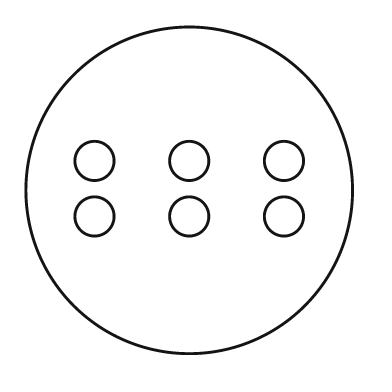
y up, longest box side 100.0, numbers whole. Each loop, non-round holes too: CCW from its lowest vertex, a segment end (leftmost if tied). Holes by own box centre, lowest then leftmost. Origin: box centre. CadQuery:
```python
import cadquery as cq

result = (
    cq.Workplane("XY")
    .moveTo(0.0, 0.0)
    .circle(50.0)
    .moveTo(-29.0, -8.0)
    .circle(6.0)
    .moveTo(0.0, -8.0)
    .circle(6.0)
    .moveTo(29.0, -8.0)
    .circle(6.0)
    .moveTo(-29.0, 9.0)
    .circle(6.0)
    .moveTo(0.0, 9.0)
    .circle(6.0)
    .moveTo(29.0, 9.0)
    .circle(6.0)
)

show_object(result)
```